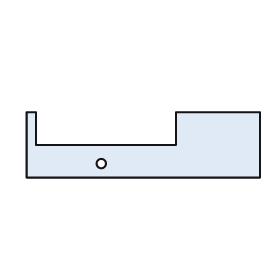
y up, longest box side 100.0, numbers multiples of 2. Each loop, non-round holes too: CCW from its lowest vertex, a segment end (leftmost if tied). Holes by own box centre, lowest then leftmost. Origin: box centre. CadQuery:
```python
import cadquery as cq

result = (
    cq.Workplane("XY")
    .moveTo(-50.0, -14.0)
    .lineTo(50.0, -14.0)
    .lineTo(50.0, 14.0)
    .lineTo(14.0, 14.0)
    .lineTo(14.0, 0.0)
    .lineTo(-46.0, 0.0)
    .lineTo(-46.0, 14.0)
    .lineTo(-50.0, 14.0)
    .close()
    .moveTo(-18.0, -8.0)
    .circle(2.0)
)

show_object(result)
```